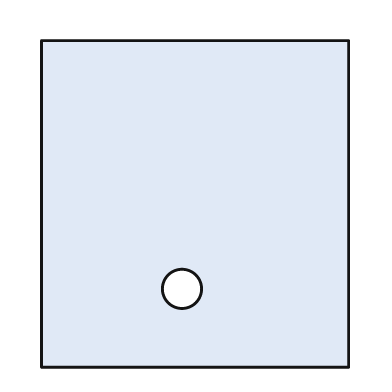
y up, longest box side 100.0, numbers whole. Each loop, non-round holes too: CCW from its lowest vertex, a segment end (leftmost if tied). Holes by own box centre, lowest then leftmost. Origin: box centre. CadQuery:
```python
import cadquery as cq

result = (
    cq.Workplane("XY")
    .moveTo(-47.0, -50.0)
    .lineTo(47.0, -50.0)
    .lineTo(47.0, 50.0)
    .lineTo(-47.0, 50.0)
    .close()
    .moveTo(-4.0, -26.0)
    .circle(6.0)
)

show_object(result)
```